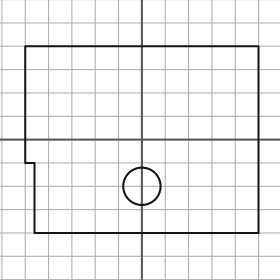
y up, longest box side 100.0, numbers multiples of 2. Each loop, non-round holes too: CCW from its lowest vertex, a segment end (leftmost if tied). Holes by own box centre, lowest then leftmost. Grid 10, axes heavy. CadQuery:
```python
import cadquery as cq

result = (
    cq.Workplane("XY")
    .moveTo(-46.0, -40.0)
    .lineTo(50.0, -40.0)
    .lineTo(50.0, 40.0)
    .lineTo(-50.0, 40.0)
    .lineTo(-50.0, -10.0)
    .lineTo(-46.0, -10.0)
    .close()
    .moveTo(0.0, -20.0)
    .circle(8.0)
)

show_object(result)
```